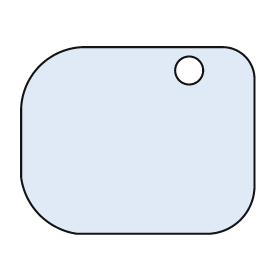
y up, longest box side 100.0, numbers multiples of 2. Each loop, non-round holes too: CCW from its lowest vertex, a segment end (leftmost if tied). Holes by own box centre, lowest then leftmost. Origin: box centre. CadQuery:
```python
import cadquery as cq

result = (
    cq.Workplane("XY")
    .moveTo(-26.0, -40.0)
    .lineTo(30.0, -40.0)
    .threePointArc((44.0, -34.0), (50.0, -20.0))
    .lineTo(50.0, 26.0)
    .threePointArc((46.0, 36.0), (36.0, 40.0))
    .lineTo(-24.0, 40.0)
    .threePointArc((-42.0, 32.0), (-50.0, 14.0))
    .lineTo(-50.0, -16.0)
    .threePointArc((-42.0, -32.0), (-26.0, -40.0))
    .close()
    .moveTo(22.0, 30.0)
    .circle(6.0)
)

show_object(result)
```